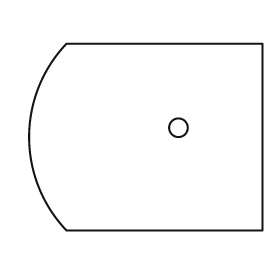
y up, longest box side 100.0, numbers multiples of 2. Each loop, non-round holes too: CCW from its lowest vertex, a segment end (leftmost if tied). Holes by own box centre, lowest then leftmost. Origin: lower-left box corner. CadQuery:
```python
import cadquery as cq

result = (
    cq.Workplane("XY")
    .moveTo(16.0, 0.0)
    .lineTo(100.0, 0.0)
    .lineTo(100.0, 80.0)
    .lineTo(16.0, 80.0)
    .threePointArc((0.0, 40.0), (16.0, 0.0))
    .close()
    .moveTo(64.0, 44.0)
    .circle(4.0)
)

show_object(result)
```